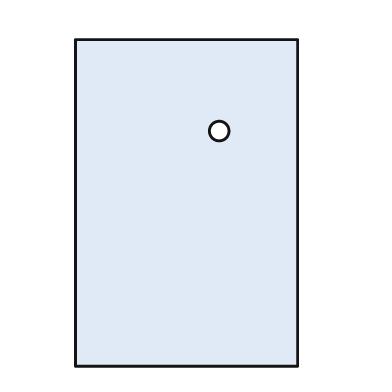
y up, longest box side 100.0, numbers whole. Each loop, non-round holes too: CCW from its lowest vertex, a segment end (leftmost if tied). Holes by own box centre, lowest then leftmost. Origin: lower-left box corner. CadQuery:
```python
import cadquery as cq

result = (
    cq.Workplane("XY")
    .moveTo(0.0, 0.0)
    .lineTo(68.0, 0.0)
    .lineTo(68.0, 100.0)
    .lineTo(0.0, 100.0)
    .close()
    .moveTo(44.0, 72.0)
    .circle(3.0)
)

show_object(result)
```